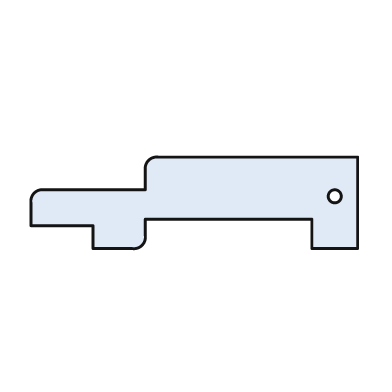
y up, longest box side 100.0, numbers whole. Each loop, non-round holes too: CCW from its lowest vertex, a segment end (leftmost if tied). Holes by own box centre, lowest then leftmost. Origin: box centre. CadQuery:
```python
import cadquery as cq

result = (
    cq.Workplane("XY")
    .moveTo(-31.0, -14.0)
    .lineTo(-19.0, -14.0)
    .threePointArc((-16.0, -13.0), (-15.0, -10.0))
    .lineTo(-15.0, -5.0)
    .lineTo(36.0, -5.0)
    .lineTo(36.0, -14.0)
    .lineTo(50.0, -14.0)
    .lineTo(50.0, 14.0)
    .lineTo(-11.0, 14.0)
    .threePointArc((-14.0, 13.0), (-15.0, 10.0))
    .lineTo(-15.0, 4.0)
    .lineTo(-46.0, 4.0)
    .threePointArc((-49.0, 3.0), (-50.0, 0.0))
    .lineTo(-50.0, -7.0)
    .lineTo(-31.0, -7.0)
    .close()
    .moveTo(43.0, 2.0)
    .circle(2.0)
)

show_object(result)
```